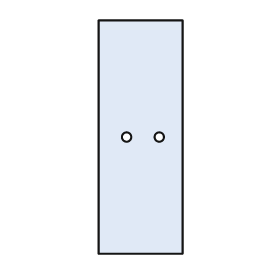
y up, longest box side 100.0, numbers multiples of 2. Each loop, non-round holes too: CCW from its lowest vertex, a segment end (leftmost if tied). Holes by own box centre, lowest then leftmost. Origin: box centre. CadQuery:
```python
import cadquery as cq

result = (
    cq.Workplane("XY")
    .moveTo(-18.0, -50.0)
    .lineTo(18.0, -50.0)
    .lineTo(18.0, 50.0)
    .lineTo(-18.0, 50.0)
    .close()
    .moveTo(-6.0, 0.0)
    .circle(2.0)
    .moveTo(8.0, 0.0)
    .circle(2.0)
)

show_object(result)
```